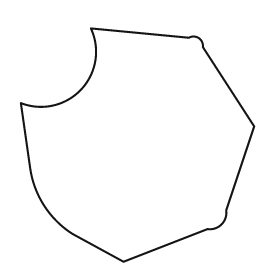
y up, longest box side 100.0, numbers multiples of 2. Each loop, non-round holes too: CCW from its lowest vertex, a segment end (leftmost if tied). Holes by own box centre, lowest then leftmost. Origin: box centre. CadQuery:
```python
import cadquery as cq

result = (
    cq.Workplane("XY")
    .moveTo(-6.0, -50.0)
    .lineTo(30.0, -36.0)
    .threePointArc((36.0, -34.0), (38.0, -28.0))
    .lineTo(50.0, 8.0)
    .lineTo(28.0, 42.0)
    .threePointArc((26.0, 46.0), (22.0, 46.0))
    .lineTo(-20.0, 50.0)
    .threePointArc((-24.0, 24.0), (-50.0, 18.0))
    .lineTo(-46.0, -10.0)
    .threePointArc((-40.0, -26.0), (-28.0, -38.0))
    .close()
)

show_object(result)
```